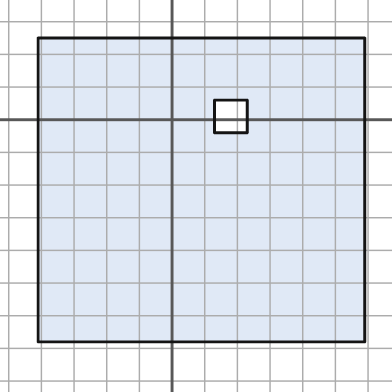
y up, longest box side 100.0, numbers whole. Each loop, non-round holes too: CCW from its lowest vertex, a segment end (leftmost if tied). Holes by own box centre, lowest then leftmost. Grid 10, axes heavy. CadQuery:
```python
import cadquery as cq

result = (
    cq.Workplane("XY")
    .moveTo(-41.0, -68.0)
    .lineTo(59.0, -68.0)
    .lineTo(59.0, 25.0)
    .lineTo(-41.0, 25.0)
    .close()
    .moveTo(13.0, -4.0)
    .lineTo(23.0, -4.0)
    .lineTo(23.0, 6.0)
    .lineTo(13.0, 6.0)
    .close()
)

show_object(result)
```